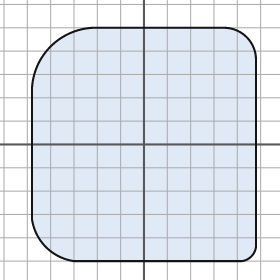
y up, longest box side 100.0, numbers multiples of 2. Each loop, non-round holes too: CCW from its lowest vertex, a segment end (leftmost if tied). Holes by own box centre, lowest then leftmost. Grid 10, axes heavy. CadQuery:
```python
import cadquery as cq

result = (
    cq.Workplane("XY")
    .moveTo(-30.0, -50.0)
    .lineTo(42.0, -50.0)
    .threePointArc((46.0, -48.0), (48.0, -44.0))
    .lineTo(48.0, 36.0)
    .threePointArc((44.0, 46.0), (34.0, 50.0))
    .lineTo(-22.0, 50.0)
    .threePointArc((-40.0, 42.0), (-48.0, 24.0))
    .lineTo(-48.0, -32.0)
    .threePointArc((-42.0, -44.0), (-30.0, -50.0))
    .close()
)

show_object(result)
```